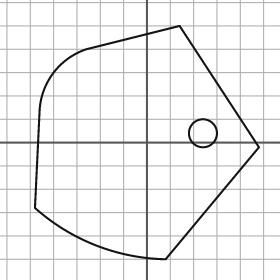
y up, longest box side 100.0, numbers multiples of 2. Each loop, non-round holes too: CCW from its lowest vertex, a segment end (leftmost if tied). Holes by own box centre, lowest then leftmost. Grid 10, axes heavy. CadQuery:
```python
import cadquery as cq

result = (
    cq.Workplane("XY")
    .moveTo(8.0, -50.0)
    .lineTo(48.0, -2.0)
    .lineTo(14.0, 50.0)
    .lineTo(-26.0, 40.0)
    .threePointArc((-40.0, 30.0), (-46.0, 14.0))
    .lineTo(-48.0, -28.0)
    .threePointArc((-22.0, -44.0), (8.0, -50.0))
    .close()
    .moveTo(24.0, 4.0)
    .circle(6.0)
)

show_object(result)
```